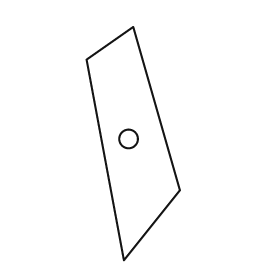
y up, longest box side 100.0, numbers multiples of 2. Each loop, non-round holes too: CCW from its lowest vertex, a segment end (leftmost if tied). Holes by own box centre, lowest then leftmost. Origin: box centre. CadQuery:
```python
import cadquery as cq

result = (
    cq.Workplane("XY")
    .moveTo(-4.0, -50.0)
    .lineTo(20.0, -20.0)
    .lineTo(0.0, 50.0)
    .lineTo(-20.0, 36.0)
    .close()
    .moveTo(-2.0, 2.0)
    .circle(4.0)
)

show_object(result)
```